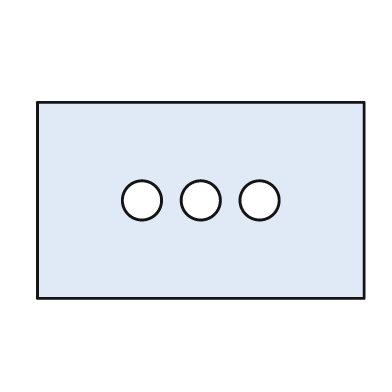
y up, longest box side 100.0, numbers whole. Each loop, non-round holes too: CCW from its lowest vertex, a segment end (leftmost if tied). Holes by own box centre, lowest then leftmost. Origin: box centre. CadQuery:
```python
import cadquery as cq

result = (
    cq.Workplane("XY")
    .moveTo(-50.0, -30.0)
    .lineTo(50.0, -30.0)
    .lineTo(50.0, 30.0)
    .lineTo(-50.0, 30.0)
    .close()
    .moveTo(-18.0, 0.0)
    .circle(6.0)
    .moveTo(0.0, 0.0)
    .circle(6.0)
    .moveTo(18.0, 0.0)
    .circle(6.0)
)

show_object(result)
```